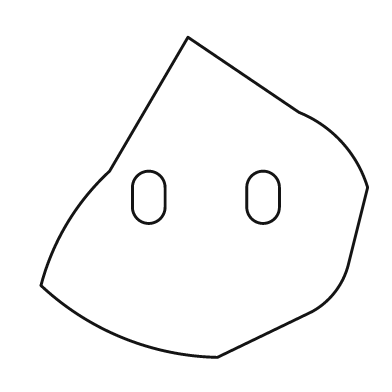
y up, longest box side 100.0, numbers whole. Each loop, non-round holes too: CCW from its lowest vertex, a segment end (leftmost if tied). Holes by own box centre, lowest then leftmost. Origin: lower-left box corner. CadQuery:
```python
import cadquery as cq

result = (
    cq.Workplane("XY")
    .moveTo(54.0, 0.0)
    .lineTo(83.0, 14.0)
    .threePointArc((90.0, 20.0), (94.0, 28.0))
    .lineTo(100.0, 52.0)
    .threePointArc((92.0, 66.0), (79.0, 75.0))
    .lineTo(45.0, 98.0)
    .lineTo(21.0, 57.0)
    .threePointArc((8.0, 41.0), (0.0, 22.0))
    .threePointArc((25.0, 6.0), (54.0, 0.0))
    .close()
    .moveTo(28.0, 46.0)
    .threePointArc((33.0, 41.0), (38.0, 46.0))
    .lineTo(38.0, 52.0)
    .threePointArc((33.0, 57.0), (28.0, 52.0))
    .close()
    .moveTo(63.0, 46.0)
    .threePointArc((68.0, 41.0), (73.0, 46.0))
    .lineTo(73.0, 52.0)
    .threePointArc((68.0, 57.0), (63.0, 52.0))
    .close()
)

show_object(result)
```